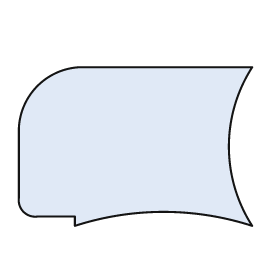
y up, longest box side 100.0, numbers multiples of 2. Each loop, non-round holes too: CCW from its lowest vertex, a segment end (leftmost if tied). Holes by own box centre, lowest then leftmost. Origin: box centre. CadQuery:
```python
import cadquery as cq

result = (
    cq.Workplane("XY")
    .moveTo(-26.0, -34.0)
    .threePointArc((12.0, -28.0), (50.0, -34.0))
    .threePointArc((40.0, 0.0), (50.0, 34.0))
    .lineTo(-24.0, 34.0)
    .threePointArc((-42.0, 26.0), (-50.0, 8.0))
    .lineTo(-50.0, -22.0)
    .threePointArc((-48.0, -28.0), (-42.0, -30.0))
    .lineTo(-26.0, -30.0)
    .close()
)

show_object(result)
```